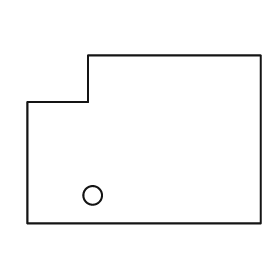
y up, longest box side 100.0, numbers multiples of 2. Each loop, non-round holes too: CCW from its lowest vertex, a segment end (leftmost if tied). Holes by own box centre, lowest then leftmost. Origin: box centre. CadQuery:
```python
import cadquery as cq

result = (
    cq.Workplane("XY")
    .moveTo(-50.0, -36.0)
    .lineTo(50.0, -36.0)
    .lineTo(50.0, 36.0)
    .lineTo(-24.0, 36.0)
    .lineTo(-24.0, 16.0)
    .lineTo(-50.0, 16.0)
    .close()
    .moveTo(-22.0, -24.0)
    .circle(4.0)
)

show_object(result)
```